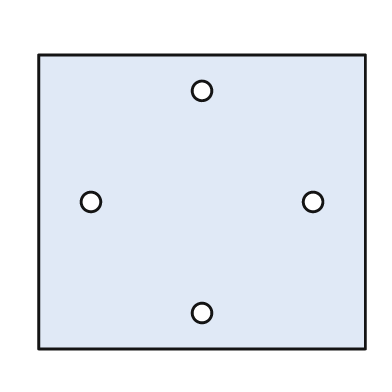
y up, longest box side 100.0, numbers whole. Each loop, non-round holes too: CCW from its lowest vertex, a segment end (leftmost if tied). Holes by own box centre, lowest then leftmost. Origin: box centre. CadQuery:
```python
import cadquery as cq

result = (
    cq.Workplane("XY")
    .moveTo(-50.0, -45.0)
    .lineTo(50.0, -45.0)
    .lineTo(50.0, 45.0)
    .lineTo(-50.0, 45.0)
    .close()
    .moveTo(0.0, -34.0)
    .circle(3.0)
    .moveTo(-34.0, 0.0)
    .circle(3.0)
    .moveTo(34.0, 0.0)
    .circle(3.0)
    .moveTo(0.0, 34.0)
    .circle(3.0)
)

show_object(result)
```